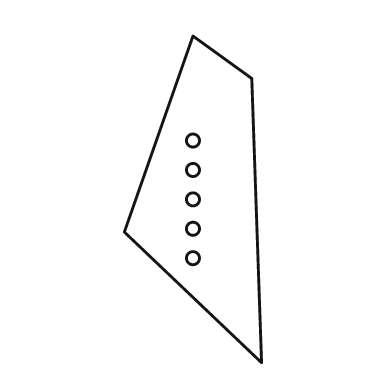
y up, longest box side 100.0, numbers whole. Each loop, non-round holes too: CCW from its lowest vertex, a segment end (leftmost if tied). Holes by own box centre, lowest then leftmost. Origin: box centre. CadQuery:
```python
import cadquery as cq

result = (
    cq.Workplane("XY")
    .moveTo(21.0, -50.0)
    .lineTo(18.0, 37.0)
    .lineTo(0.0, 50.0)
    .lineTo(-21.0, -10.0)
    .close()
    .moveTo(0.0, -18.0)
    .circle(2.0)
    .moveTo(0.0, -9.0)
    .circle(2.0)
    .moveTo(0.0, 0.0)
    .circle(2.0)
    .moveTo(0.0, 9.0)
    .circle(2.0)
    .moveTo(0.0, 18.0)
    .circle(2.0)
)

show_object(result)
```